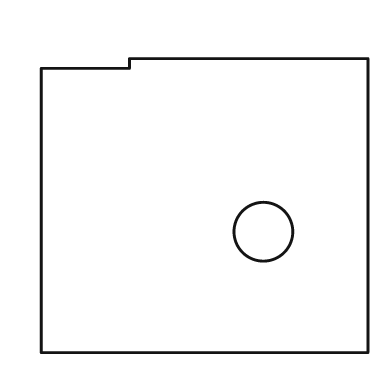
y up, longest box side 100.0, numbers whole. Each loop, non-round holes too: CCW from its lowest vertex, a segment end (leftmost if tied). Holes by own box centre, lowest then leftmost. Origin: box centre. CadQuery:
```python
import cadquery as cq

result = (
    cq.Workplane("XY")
    .moveTo(-50.0, -45.0)
    .lineTo(50.0, -45.0)
    .lineTo(50.0, 45.0)
    .lineTo(-23.0, 45.0)
    .lineTo(-23.0, 42.0)
    .lineTo(-50.0, 42.0)
    .close()
    .moveTo(18.0, -8.0)
    .circle(9.0)
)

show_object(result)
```